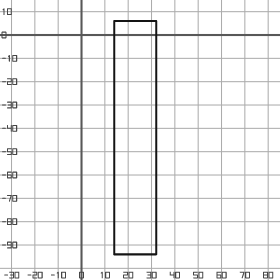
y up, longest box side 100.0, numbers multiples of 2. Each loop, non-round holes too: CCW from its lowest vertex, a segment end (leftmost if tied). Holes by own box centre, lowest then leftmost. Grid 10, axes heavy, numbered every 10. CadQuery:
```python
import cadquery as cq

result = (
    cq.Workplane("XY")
    .moveTo(14.0, -94.0)
    .lineTo(32.0, -94.0)
    .lineTo(32.0, 6.0)
    .lineTo(14.0, 6.0)
    .close()
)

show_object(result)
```